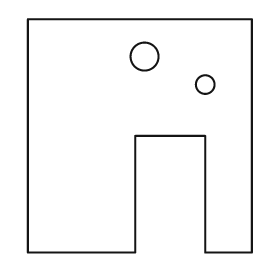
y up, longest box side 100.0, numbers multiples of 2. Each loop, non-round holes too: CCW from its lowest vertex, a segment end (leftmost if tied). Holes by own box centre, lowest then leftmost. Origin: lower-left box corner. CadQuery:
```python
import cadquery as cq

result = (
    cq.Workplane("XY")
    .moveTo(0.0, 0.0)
    .lineTo(46.0, 0.0)
    .lineTo(46.0, 50.0)
    .lineTo(76.0, 50.0)
    .lineTo(76.0, 0.0)
    .lineTo(96.0, 0.0)
    .lineTo(96.0, 100.0)
    .lineTo(0.0, 100.0)
    .close()
    .moveTo(76.0, 72.0)
    .circle(4.0)
    .moveTo(50.0, 84.0)
    .circle(6.0)
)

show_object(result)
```